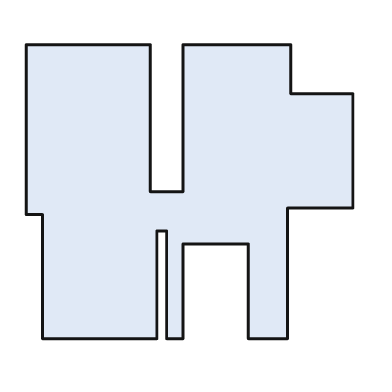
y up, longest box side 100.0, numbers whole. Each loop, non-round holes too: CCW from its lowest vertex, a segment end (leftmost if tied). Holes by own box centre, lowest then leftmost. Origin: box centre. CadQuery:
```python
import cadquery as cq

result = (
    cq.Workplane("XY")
    .moveTo(-45.0, -45.0)
    .lineTo(-10.0, -45.0)
    .lineTo(-10.0, -12.0)
    .lineTo(-7.0, -12.0)
    .lineTo(-7.0, -45.0)
    .lineTo(-2.0, -45.0)
    .lineTo(-2.0, -16.0)
    .lineTo(18.0, -16.0)
    .lineTo(18.0, -45.0)
    .lineTo(30.0, -45.0)
    .lineTo(30.0, -5.0)
    .lineTo(50.0, -5.0)
    .lineTo(50.0, 30.0)
    .lineTo(31.0, 30.0)
    .lineTo(31.0, 45.0)
    .lineTo(-2.0, 45.0)
    .lineTo(-2.0, 0.0)
    .lineTo(-12.0, 0.0)
    .lineTo(-12.0, 45.0)
    .lineTo(-50.0, 45.0)
    .lineTo(-50.0, -7.0)
    .lineTo(-45.0, -7.0)
    .close()
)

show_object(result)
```